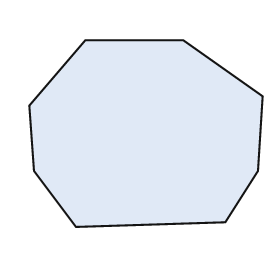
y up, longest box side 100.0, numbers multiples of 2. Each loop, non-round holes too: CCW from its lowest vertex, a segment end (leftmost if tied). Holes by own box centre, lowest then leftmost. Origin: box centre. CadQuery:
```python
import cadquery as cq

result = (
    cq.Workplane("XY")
    .moveTo(-30.0, -40.0)
    .lineTo(34.0, -38.0)
    .lineTo(48.0, -16.0)
    .lineTo(50.0, 16.0)
    .lineTo(16.0, 40.0)
    .lineTo(-26.0, 40.0)
    .lineTo(-50.0, 12.0)
    .lineTo(-48.0, -16.0)
    .close()
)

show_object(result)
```